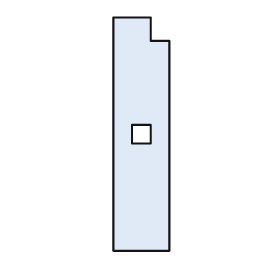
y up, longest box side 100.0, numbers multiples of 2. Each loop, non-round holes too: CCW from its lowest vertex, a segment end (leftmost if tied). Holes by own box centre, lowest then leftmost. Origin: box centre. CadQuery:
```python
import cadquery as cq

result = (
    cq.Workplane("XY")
    .moveTo(-12.0, -50.0)
    .lineTo(12.0, -50.0)
    .lineTo(12.0, 40.0)
    .lineTo(4.0, 40.0)
    .lineTo(4.0, 50.0)
    .lineTo(-12.0, 50.0)
    .close()
    .moveTo(-4.0, -4.0)
    .lineTo(4.0, -4.0)
    .lineTo(4.0, 4.0)
    .lineTo(-4.0, 4.0)
    .close()
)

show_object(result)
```